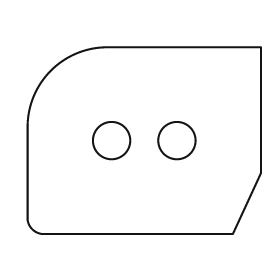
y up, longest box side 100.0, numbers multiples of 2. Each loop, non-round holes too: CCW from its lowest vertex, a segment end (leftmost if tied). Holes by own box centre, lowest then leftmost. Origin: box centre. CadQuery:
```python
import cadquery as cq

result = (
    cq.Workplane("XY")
    .moveTo(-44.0, -40.0)
    .lineTo(38.0, -40.0)
    .lineTo(50.0, -14.0)
    .lineTo(50.0, 40.0)
    .lineTo(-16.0, 40.0)
    .threePointArc((-40.0, 30.0), (-50.0, 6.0))
    .lineTo(-50.0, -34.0)
    .threePointArc((-48.0, -38.0), (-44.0, -40.0))
    .close()
    .moveTo(-14.0, 0.0)
    .circle(8.0)
    .moveTo(14.0, 0.0)
    .circle(8.0)
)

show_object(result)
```